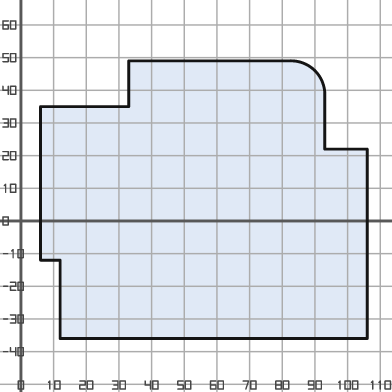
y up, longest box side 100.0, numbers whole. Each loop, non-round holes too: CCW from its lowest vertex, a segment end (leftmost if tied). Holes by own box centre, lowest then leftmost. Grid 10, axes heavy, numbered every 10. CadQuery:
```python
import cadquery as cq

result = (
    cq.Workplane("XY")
    .moveTo(12.0, -36.0)
    .lineTo(106.0, -36.0)
    .lineTo(106.0, 22.0)
    .lineTo(93.0, 22.0)
    .lineTo(93.0, 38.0)
    .threePointArc((90.0, 46.0), (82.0, 49.0))
    .lineTo(33.0, 49.0)
    .lineTo(33.0, 35.0)
    .lineTo(6.0, 35.0)
    .lineTo(6.0, -12.0)
    .lineTo(12.0, -12.0)
    .close()
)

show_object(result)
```